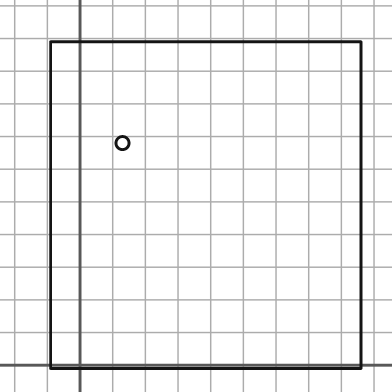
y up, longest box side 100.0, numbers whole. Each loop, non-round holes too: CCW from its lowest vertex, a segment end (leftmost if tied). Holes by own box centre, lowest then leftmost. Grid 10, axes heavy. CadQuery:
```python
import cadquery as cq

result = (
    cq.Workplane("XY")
    .moveTo(-9.0, -1.0)
    .lineTo(86.0, -1.0)
    .lineTo(86.0, 99.0)
    .lineTo(-9.0, 99.0)
    .close()
    .moveTo(13.0, 68.0)
    .circle(2.0)
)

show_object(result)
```